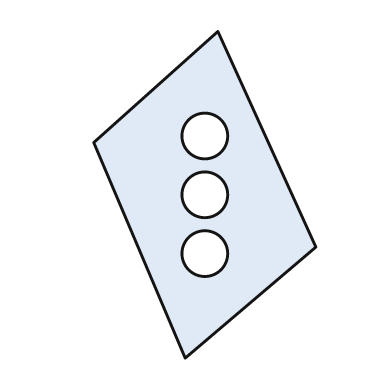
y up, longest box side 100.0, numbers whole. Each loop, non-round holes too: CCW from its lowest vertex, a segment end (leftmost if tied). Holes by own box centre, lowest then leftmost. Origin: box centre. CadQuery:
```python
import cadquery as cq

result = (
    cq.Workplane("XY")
    .moveTo(-6.0, -50.0)
    .lineTo(34.0, -16.0)
    .lineTo(4.0, 50.0)
    .lineTo(-34.0, 16.0)
    .close()
    .moveTo(0.0, -18.0)
    .circle(7.0)
    .moveTo(0.0, 0.0)
    .circle(7.0)
    .moveTo(0.0, 18.0)
    .circle(7.0)
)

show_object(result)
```